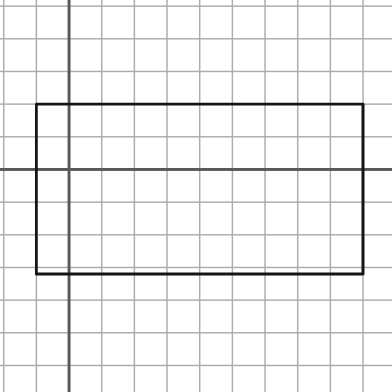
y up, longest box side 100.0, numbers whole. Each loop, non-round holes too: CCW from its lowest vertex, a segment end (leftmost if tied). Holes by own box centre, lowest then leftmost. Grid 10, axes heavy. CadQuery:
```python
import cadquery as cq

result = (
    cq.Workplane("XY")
    .moveTo(-10.0, -32.0)
    .lineTo(90.0, -32.0)
    .lineTo(90.0, 20.0)
    .lineTo(-10.0, 20.0)
    .close()
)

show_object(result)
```